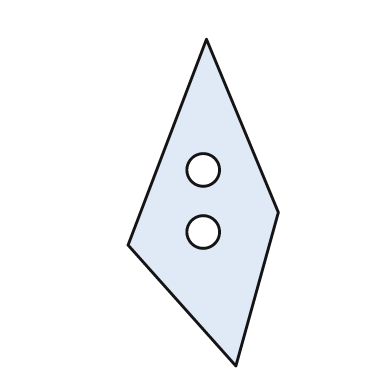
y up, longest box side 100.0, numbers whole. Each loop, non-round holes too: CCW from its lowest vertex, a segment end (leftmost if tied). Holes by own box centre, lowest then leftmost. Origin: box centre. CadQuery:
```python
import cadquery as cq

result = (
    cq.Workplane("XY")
    .moveTo(10.0, -50.0)
    .lineTo(23.0, -3.0)
    .lineTo(1.0, 50.0)
    .lineTo(-23.0, -13.0)
    .close()
    .moveTo(0.0, -9.0)
    .circle(5.0)
    .moveTo(0.0, 10.0)
    .circle(5.0)
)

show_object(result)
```